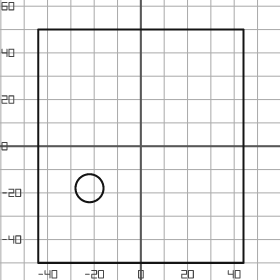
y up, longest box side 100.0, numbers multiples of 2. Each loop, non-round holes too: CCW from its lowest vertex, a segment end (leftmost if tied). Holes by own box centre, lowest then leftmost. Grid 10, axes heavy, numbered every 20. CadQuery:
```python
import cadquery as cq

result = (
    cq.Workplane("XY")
    .moveTo(-44.0, -50.0)
    .lineTo(44.0, -50.0)
    .lineTo(44.0, 50.0)
    .lineTo(-44.0, 50.0)
    .close()
    .moveTo(-22.0, -18.0)
    .circle(6.0)
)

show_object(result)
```